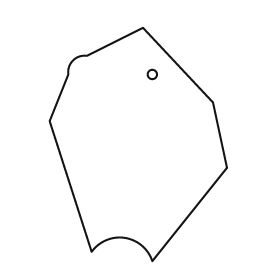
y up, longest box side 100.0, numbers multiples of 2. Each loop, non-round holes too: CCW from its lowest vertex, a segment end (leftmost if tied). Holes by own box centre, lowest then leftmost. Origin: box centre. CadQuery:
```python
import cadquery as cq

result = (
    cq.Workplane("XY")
    .moveTo(6.0, -50.0)
    .lineTo(38.0, -10.0)
    .lineTo(32.0, 18.0)
    .lineTo(2.0, 50.0)
    .lineTo(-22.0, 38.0)
    .threePointArc((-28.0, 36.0), (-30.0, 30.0))
    .lineTo(-38.0, 10.0)
    .lineTo(-20.0, -46.0)
    .threePointArc((-6.0, -40.0), (6.0, -50.0))
    .close()
    .moveTo(6.0, 30.0)
    .circle(2.0)
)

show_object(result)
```